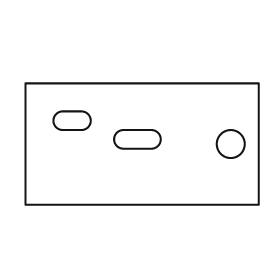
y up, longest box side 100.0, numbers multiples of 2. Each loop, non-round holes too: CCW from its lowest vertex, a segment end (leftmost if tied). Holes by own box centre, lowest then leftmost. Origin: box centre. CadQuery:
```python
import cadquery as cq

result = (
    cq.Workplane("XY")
    .moveTo(-50.0, -26.0)
    .lineTo(50.0, -26.0)
    .lineTo(50.0, 26.0)
    .lineTo(-50.0, 26.0)
    .close()
    .moveTo(38.0, 0.0)
    .circle(6.0)
    .moveTo(-8.0, -2.0)
    .lineTo(4.0, -2.0)
    .threePointArc((8.0, 2.0), (4.0, 6.0))
    .lineTo(-8.0, 6.0)
    .threePointArc((-12.0, 2.0), (-8.0, -2.0))
    .close()
    .moveTo(-34.0, 6.0)
    .lineTo(-26.0, 6.0)
    .threePointArc((-22.0, 10.0), (-26.0, 14.0))
    .lineTo(-34.0, 14.0)
    .threePointArc((-38.0, 10.0), (-34.0, 6.0))
    .close()
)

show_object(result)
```